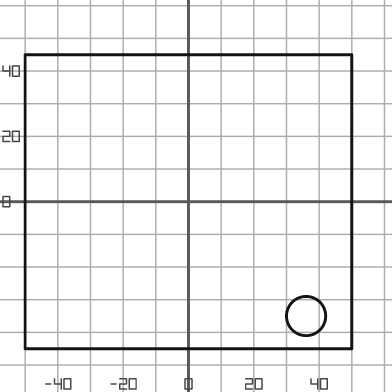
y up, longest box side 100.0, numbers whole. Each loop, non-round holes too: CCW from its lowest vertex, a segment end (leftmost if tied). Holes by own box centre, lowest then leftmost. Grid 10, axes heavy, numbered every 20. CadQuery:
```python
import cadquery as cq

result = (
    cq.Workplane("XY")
    .moveTo(-50.0, -45.0)
    .lineTo(50.0, -45.0)
    .lineTo(50.0, 45.0)
    .lineTo(-50.0, 45.0)
    .close()
    .moveTo(36.0, -35.0)
    .circle(6.0)
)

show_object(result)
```